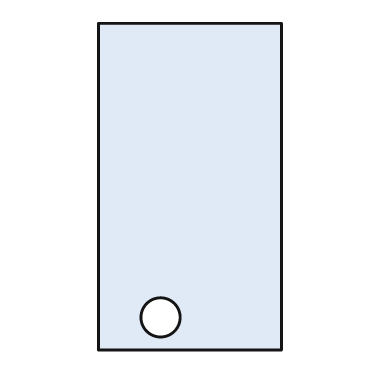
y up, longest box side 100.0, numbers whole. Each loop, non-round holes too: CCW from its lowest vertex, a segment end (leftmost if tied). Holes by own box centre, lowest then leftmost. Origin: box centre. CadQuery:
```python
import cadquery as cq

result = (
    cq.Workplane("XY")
    .moveTo(-28.0, -50.0)
    .lineTo(28.0, -50.0)
    .lineTo(28.0, 50.0)
    .lineTo(-28.0, 50.0)
    .close()
    .moveTo(-9.0, -40.0)
    .circle(6.0)
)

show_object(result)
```